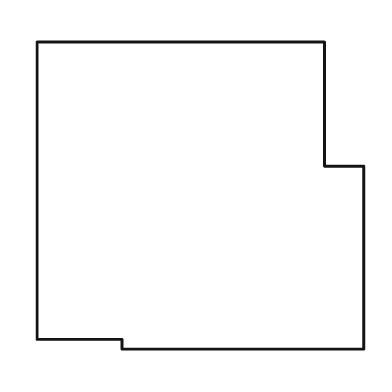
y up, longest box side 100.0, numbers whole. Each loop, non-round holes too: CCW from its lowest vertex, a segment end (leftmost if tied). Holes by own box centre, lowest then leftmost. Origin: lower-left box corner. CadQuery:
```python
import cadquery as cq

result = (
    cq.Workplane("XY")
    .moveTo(26.0, 0.0)
    .lineTo(100.0, 0.0)
    .lineTo(100.0, 56.0)
    .lineTo(88.0, 56.0)
    .lineTo(88.0, 94.0)
    .lineTo(0.0, 94.0)
    .lineTo(0.0, 3.0)
    .lineTo(26.0, 3.0)
    .close()
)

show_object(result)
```